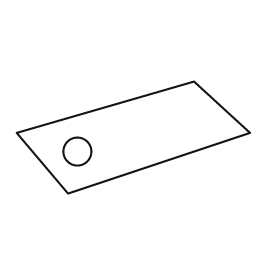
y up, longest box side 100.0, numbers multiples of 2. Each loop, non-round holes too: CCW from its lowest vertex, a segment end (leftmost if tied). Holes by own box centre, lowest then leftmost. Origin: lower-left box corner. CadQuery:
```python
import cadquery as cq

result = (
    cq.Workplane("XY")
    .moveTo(22.0, 0.0)
    .lineTo(100.0, 26.0)
    .lineTo(76.0, 48.0)
    .lineTo(0.0, 26.0)
    .close()
    .moveTo(26.0, 18.0)
    .circle(6.0)
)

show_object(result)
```